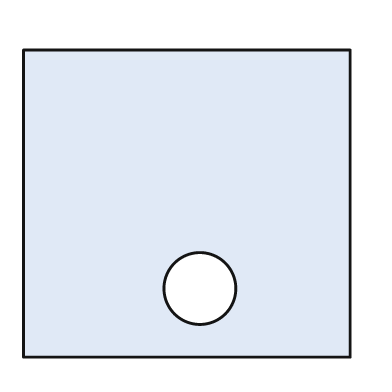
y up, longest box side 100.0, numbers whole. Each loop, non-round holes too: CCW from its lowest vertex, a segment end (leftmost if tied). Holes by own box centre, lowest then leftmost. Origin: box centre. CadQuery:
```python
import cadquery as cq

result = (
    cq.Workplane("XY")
    .moveTo(-50.0, -47.0)
    .lineTo(50.0, -47.0)
    .lineTo(50.0, 47.0)
    .lineTo(-50.0, 47.0)
    .close()
    .moveTo(4.0, -26.0)
    .circle(11.0)
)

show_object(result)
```